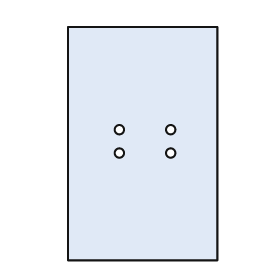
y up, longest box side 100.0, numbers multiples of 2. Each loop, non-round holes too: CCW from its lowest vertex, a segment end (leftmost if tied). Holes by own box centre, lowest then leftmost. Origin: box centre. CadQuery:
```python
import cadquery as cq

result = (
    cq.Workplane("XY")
    .moveTo(-32.0, -50.0)
    .lineTo(32.0, -50.0)
    .lineTo(32.0, 50.0)
    .lineTo(-32.0, 50.0)
    .close()
    .moveTo(-10.0, -4.0)
    .circle(2.0)
    .moveTo(12.0, -4.0)
    .circle(2.0)
    .moveTo(-10.0, 6.0)
    .circle(2.0)
    .moveTo(12.0, 6.0)
    .circle(2.0)
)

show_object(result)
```